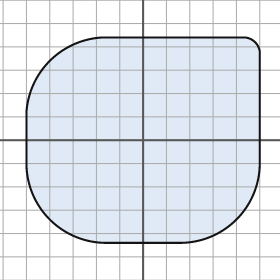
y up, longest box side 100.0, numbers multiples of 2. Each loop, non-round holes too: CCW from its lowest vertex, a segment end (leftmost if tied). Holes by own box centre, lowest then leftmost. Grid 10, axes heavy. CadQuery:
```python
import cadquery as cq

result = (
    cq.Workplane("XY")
    .moveTo(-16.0, -44.0)
    .lineTo(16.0, -44.0)
    .threePointArc((40.0, -34.0), (50.0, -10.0))
    .lineTo(50.0, 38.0)
    .threePointArc((48.0, 42.0), (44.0, 44.0))
    .lineTo(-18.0, 44.0)
    .threePointArc((-40.0, 34.0), (-50.0, 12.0))
    .lineTo(-50.0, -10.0)
    .threePointArc((-40.0, -34.0), (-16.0, -44.0))
    .close()
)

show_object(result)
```